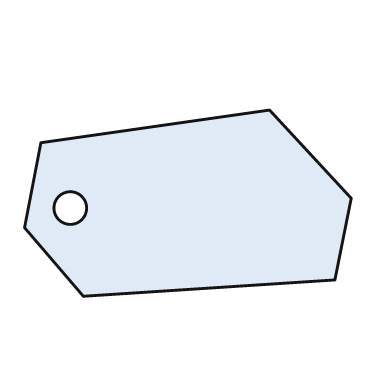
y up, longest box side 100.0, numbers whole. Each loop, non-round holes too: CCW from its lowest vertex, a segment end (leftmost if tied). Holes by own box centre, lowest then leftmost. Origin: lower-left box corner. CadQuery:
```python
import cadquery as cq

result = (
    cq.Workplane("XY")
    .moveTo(18.0, 0.0)
    .lineTo(95.0, 5.0)
    .lineTo(100.0, 30.0)
    .lineTo(75.0, 57.0)
    .lineTo(5.0, 47.0)
    .lineTo(0.0, 21.0)
    .close()
    .moveTo(14.0, 27.0)
    .circle(5.0)
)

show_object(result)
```